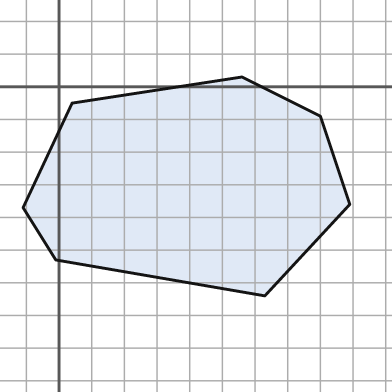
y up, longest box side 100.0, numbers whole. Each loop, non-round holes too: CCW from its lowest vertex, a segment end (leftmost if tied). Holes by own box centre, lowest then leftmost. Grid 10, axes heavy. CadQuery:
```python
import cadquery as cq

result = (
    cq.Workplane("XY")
    .moveTo(63.0, -64.0)
    .lineTo(89.0, -36.0)
    .lineTo(80.0, -9.0)
    .lineTo(56.0, 3.0)
    .lineTo(4.0, -5.0)
    .lineTo(-11.0, -37.0)
    .lineTo(-1.0, -53.0)
    .close()
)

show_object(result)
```